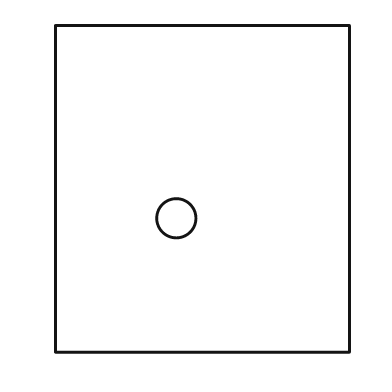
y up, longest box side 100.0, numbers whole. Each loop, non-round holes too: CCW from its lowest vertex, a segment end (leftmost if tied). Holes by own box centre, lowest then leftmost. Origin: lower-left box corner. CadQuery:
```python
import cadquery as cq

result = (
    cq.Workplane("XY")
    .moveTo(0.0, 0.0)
    .lineTo(90.0, 0.0)
    .lineTo(90.0, 100.0)
    .lineTo(0.0, 100.0)
    .close()
    .moveTo(37.0, 41.0)
    .circle(6.0)
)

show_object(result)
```